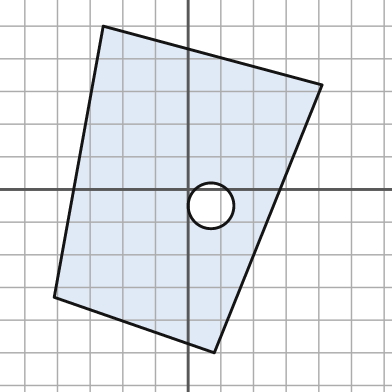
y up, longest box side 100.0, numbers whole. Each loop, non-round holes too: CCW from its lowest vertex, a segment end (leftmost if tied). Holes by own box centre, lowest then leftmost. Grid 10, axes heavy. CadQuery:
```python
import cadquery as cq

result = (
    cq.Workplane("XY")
    .moveTo(8.0, -50.0)
    .lineTo(41.0, 32.0)
    .lineTo(-26.0, 50.0)
    .lineTo(-41.0, -33.0)
    .close()
    .moveTo(7.0, -5.0)
    .circle(7.0)
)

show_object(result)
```